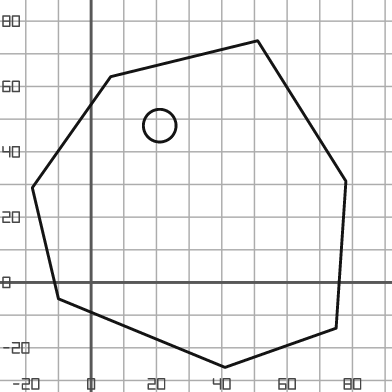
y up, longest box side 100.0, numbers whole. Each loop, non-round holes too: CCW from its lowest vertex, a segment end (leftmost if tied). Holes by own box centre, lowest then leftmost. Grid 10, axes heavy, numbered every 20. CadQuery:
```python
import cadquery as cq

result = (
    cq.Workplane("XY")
    .moveTo(41.0, -26.0)
    .lineTo(75.0, -14.0)
    .lineTo(78.0, 31.0)
    .lineTo(51.0, 74.0)
    .lineTo(6.0, 63.0)
    .lineTo(-18.0, 29.0)
    .lineTo(-10.0, -5.0)
    .close()
    .moveTo(21.0, 48.0)
    .circle(5.0)
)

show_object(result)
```